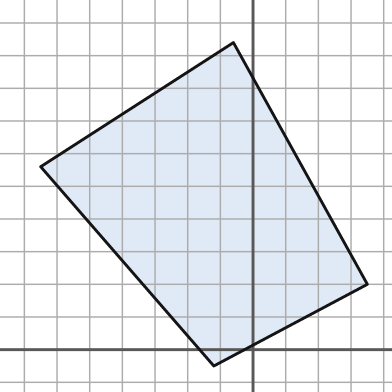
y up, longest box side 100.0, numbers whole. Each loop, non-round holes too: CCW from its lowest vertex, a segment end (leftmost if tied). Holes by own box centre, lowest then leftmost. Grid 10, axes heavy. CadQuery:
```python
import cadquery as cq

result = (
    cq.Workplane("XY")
    .moveTo(-12.0, -5.0)
    .lineTo(35.0, 20.0)
    .lineTo(-6.0, 94.0)
    .lineTo(-65.0, 56.0)
    .close()
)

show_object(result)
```